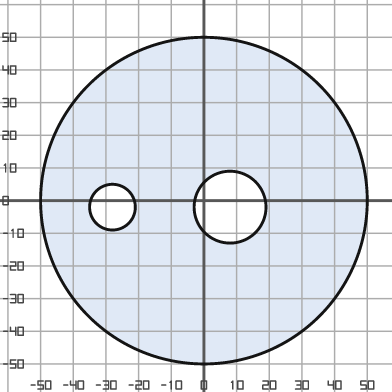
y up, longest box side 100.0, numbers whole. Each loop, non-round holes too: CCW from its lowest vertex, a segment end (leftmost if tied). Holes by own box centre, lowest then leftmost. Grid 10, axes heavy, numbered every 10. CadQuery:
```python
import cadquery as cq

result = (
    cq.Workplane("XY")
    .moveTo(0.0, 0.0)
    .circle(50.0)
    .moveTo(-28.0, -2.0)
    .circle(7.0)
    .moveTo(8.0, -2.0)
    .circle(11.0)
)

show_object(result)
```